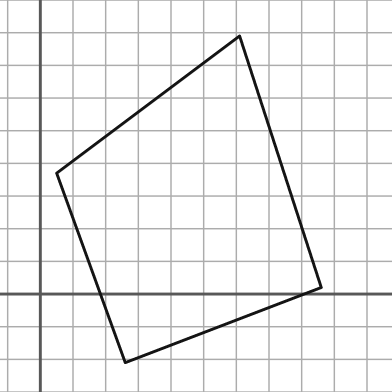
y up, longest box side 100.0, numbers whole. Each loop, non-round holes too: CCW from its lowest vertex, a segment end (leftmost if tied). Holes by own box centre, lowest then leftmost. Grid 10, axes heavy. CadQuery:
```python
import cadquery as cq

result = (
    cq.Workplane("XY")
    .moveTo(26.0, -21.0)
    .lineTo(86.0, 2.0)
    .lineTo(61.0, 79.0)
    .lineTo(5.0, 37.0)
    .close()
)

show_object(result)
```